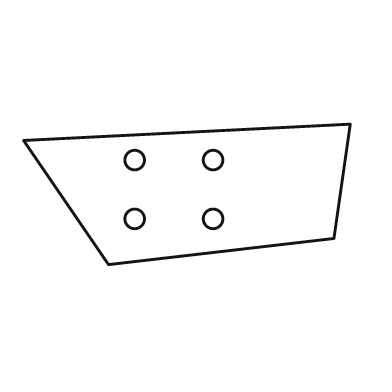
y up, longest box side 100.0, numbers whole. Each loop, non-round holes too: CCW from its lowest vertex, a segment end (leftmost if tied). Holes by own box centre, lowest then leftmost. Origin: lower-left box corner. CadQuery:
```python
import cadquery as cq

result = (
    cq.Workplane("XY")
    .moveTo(26.0, 0.0)
    .lineTo(95.0, 8.0)
    .lineTo(100.0, 43.0)
    .lineTo(0.0, 38.0)
    .close()
    .moveTo(34.0, 14.0)
    .circle(3.0)
    .moveTo(58.0, 14.0)
    .circle(3.0)
    .moveTo(34.0, 32.0)
    .circle(3.0)
    .moveTo(58.0, 32.0)
    .circle(3.0)
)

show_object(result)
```